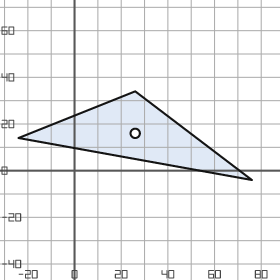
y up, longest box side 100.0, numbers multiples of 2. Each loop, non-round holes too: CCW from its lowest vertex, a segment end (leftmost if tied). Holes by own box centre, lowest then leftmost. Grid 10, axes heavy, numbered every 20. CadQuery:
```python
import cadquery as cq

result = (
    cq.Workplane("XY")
    .moveTo(76.0, -4.0)
    .lineTo(26.0, 34.0)
    .lineTo(-24.0, 14.0)
    .close()
    .moveTo(26.0, 16.0)
    .circle(2.0)
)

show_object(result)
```